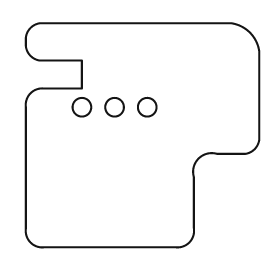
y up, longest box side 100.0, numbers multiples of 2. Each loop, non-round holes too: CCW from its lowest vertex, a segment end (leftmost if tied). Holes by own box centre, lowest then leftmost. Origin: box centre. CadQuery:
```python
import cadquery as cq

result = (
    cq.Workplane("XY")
    .moveTo(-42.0, -48.0)
    .lineTo(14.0, -48.0)
    .threePointArc((20.0, -46.0), (22.0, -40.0))
    .lineTo(22.0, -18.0)
    .threePointArc((24.0, -10.0), (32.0, -8.0))
    .lineTo(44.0, -8.0)
    .threePointArc((48.0, -6.0), (50.0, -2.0))
    .lineTo(50.0, 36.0)
    .threePointArc((46.0, 44.0), (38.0, 48.0))
    .lineTo(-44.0, 48.0)
    .threePointArc((-48.0, 46.0), (-50.0, 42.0))
    .lineTo(-50.0, 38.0)
    .threePointArc((-48.0, 34.0), (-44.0, 32.0))
    .lineTo(-26.0, 32.0)
    .lineTo(-26.0, 20.0)
    .lineTo(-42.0, 20.0)
    .threePointArc((-48.0, 18.0), (-50.0, 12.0))
    .lineTo(-50.0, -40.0)
    .threePointArc((-48.0, -46.0), (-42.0, -48.0))
    .close()
    .moveTo(-26.0, 12.0)
    .circle(4.0)
    .moveTo(-12.0, 12.0)
    .circle(4.0)
    .moveTo(2.0, 12.0)
    .circle(4.0)
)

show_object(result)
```